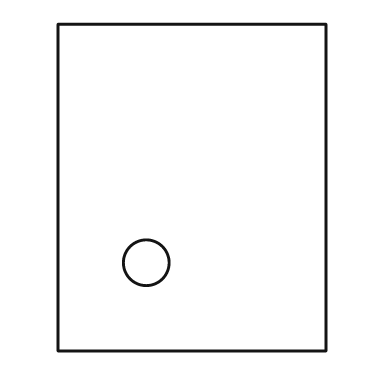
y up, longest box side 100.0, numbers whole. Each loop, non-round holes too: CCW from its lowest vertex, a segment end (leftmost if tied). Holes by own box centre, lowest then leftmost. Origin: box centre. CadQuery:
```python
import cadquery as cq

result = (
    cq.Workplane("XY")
    .moveTo(-41.0, -50.0)
    .lineTo(41.0, -50.0)
    .lineTo(41.0, 50.0)
    .lineTo(-41.0, 50.0)
    .close()
    .moveTo(-14.0, -23.0)
    .circle(7.0)
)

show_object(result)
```